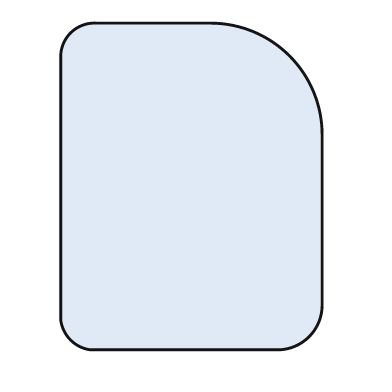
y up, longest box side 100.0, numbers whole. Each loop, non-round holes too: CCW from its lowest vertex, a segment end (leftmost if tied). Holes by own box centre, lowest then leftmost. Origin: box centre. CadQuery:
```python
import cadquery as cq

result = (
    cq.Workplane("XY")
    .moveTo(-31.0, -50.0)
    .lineTo(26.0, -50.0)
    .threePointArc((36.0, -46.0), (40.0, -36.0))
    .lineTo(40.0, 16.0)
    .threePointArc((30.0, 40.0), (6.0, 50.0))
    .lineTo(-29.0, 50.0)
    .threePointArc((-37.0, 47.0), (-40.0, 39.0))
    .lineTo(-40.0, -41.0)
    .threePointArc((-37.0, -47.0), (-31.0, -50.0))
    .close()
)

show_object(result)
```